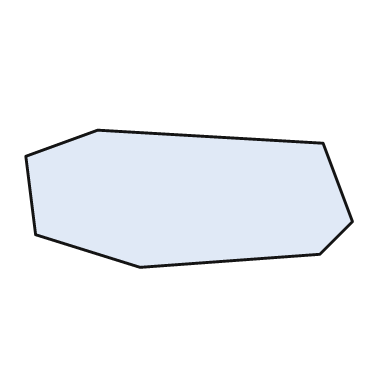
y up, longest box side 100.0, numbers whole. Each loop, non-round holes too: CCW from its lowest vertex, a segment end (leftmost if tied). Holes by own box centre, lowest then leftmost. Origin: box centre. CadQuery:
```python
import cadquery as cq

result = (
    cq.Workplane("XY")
    .moveTo(-15.0, -21.0)
    .lineTo(40.0, -17.0)
    .lineTo(50.0, -7.0)
    .lineTo(41.0, 17.0)
    .lineTo(-28.0, 21.0)
    .lineTo(-50.0, 13.0)
    .lineTo(-47.0, -11.0)
    .close()
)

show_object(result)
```